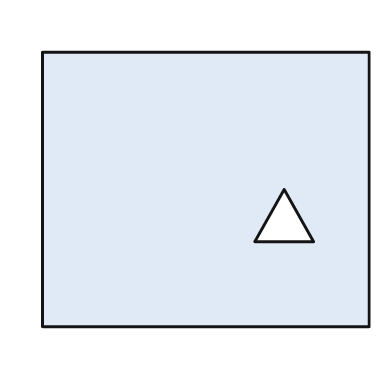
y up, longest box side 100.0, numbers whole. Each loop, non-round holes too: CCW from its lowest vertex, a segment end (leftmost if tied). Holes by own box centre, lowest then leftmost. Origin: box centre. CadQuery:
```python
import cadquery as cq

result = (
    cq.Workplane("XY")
    .moveTo(-50.0, -42.0)
    .lineTo(50.0, -42.0)
    .lineTo(50.0, 42.0)
    .lineTo(-50.0, 42.0)
    .close()
    .moveTo(15.0, -16.0)
    .lineTo(33.0, -16.0)
    .lineTo(24.0, 0.0)
    .close()
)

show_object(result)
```